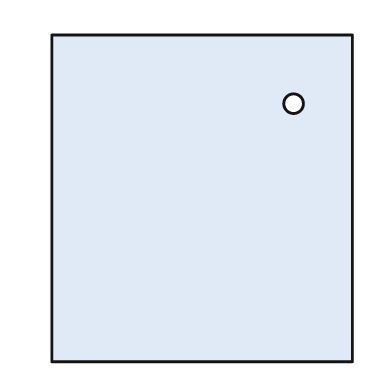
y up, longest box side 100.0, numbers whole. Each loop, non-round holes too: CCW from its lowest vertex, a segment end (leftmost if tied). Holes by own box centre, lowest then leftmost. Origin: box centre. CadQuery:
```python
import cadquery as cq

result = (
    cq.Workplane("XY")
    .moveTo(-46.0, -50.0)
    .lineTo(46.0, -50.0)
    .lineTo(46.0, 50.0)
    .lineTo(-46.0, 50.0)
    .close()
    .moveTo(28.0, 29.0)
    .circle(3.0)
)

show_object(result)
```